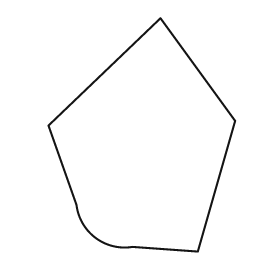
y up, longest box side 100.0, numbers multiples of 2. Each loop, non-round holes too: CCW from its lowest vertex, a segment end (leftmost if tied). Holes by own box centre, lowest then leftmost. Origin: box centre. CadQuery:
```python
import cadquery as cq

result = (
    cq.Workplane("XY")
    .moveTo(24.0, -50.0)
    .lineTo(40.0, 6.0)
    .lineTo(8.0, 50.0)
    .lineTo(-40.0, 4.0)
    .lineTo(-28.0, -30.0)
    .threePointArc((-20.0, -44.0), (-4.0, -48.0))
    .close()
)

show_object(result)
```